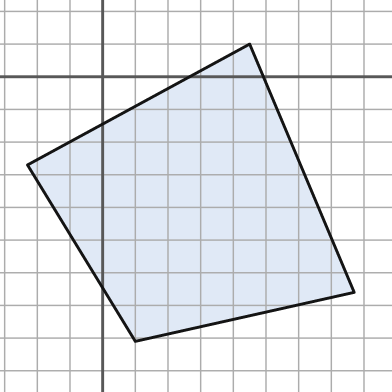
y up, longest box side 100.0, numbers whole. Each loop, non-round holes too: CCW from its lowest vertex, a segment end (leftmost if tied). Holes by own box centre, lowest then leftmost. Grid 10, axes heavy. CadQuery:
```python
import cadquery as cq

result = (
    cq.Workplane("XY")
    .moveTo(10.0, -81.0)
    .lineTo(77.0, -66.0)
    .lineTo(45.0, 10.0)
    .lineTo(-23.0, -27.0)
    .close()
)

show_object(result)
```